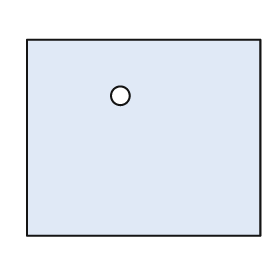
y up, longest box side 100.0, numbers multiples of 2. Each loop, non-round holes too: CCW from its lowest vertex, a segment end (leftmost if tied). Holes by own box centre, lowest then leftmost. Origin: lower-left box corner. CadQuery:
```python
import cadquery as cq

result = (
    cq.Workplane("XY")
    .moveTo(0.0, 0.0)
    .lineTo(100.0, 0.0)
    .lineTo(100.0, 84.0)
    .lineTo(0.0, 84.0)
    .close()
    .moveTo(40.0, 60.0)
    .circle(4.0)
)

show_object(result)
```